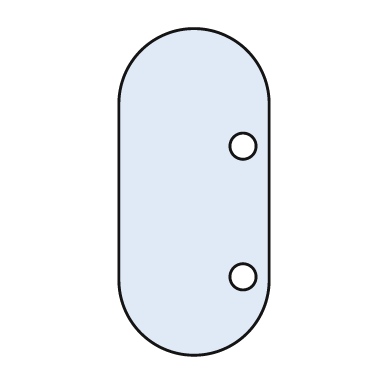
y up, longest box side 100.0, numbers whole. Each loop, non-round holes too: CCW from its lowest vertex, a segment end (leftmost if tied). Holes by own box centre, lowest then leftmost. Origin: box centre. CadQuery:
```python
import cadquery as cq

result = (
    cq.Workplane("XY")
    .moveTo(-23.0, -27.0)
    .threePointArc((0.0, -50.0), (23.0, -27.0))
    .lineTo(23.0, 27.0)
    .threePointArc((0.0, 50.0), (-23.0, 27.0))
    .close()
    .moveTo(15.0, -26.0)
    .circle(4.0)
    .moveTo(15.0, 14.0)
    .circle(4.0)
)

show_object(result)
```